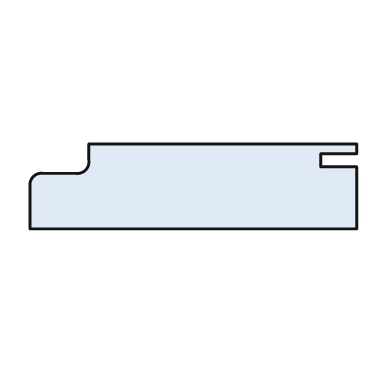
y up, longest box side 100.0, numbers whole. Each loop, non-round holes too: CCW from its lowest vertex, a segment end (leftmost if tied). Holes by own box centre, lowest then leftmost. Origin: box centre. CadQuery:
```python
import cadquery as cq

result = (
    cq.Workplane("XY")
    .moveTo(-50.0, -13.0)
    .lineTo(50.0, -13.0)
    .lineTo(50.0, 6.0)
    .lineTo(39.0, 6.0)
    .lineTo(39.0, 10.0)
    .lineTo(50.0, 10.0)
    .lineTo(50.0, 13.0)
    .lineTo(-32.0, 13.0)
    .lineTo(-32.0, 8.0)
    .threePointArc((-33.0, 5.0), (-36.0, 4.0))
    .lineTo(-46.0, 4.0)
    .threePointArc((-49.0, 3.0), (-50.0, 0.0))
    .close()
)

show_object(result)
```